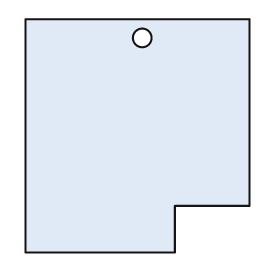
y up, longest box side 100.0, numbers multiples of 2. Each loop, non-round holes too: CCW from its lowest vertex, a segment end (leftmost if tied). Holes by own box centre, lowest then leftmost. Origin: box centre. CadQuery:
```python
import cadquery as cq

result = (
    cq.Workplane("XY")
    .moveTo(-48.0, -50.0)
    .lineTo(16.0, -50.0)
    .lineTo(16.0, -30.0)
    .lineTo(48.0, -30.0)
    .lineTo(48.0, 50.0)
    .lineTo(-48.0, 50.0)
    .close()
    .moveTo(2.0, 42.0)
    .circle(4.0)
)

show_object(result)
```